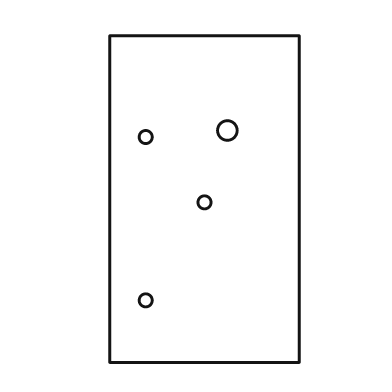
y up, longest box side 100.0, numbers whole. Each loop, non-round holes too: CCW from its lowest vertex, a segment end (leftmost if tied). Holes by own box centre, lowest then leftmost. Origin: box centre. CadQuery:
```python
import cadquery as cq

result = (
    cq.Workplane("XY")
    .moveTo(-29.0, -50.0)
    .lineTo(29.0, -50.0)
    .lineTo(29.0, 50.0)
    .lineTo(-29.0, 50.0)
    .close()
    .moveTo(-18.0, -31.0)
    .circle(2.0)
    .moveTo(0.0, -1.0)
    .circle(2.0)
    .moveTo(-18.0, 19.0)
    .circle(2.0)
    .moveTo(7.0, 21.0)
    .circle(3.0)
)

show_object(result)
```